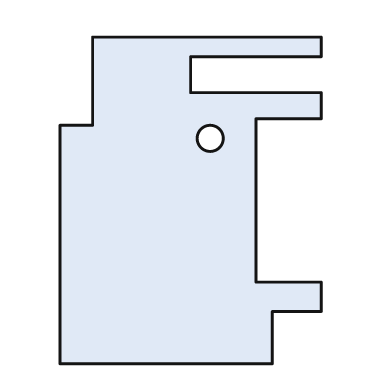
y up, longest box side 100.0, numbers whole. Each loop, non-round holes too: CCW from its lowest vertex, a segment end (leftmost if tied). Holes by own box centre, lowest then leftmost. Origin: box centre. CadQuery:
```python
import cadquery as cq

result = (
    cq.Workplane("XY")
    .moveTo(-40.0, -50.0)
    .lineTo(25.0, -50.0)
    .lineTo(25.0, -34.0)
    .lineTo(40.0, -34.0)
    .lineTo(40.0, -25.0)
    .lineTo(20.0, -25.0)
    .lineTo(20.0, 25.0)
    .lineTo(40.0, 25.0)
    .lineTo(40.0, 33.0)
    .lineTo(0.0, 33.0)
    .lineTo(0.0, 44.0)
    .lineTo(40.0, 44.0)
    .lineTo(40.0, 50.0)
    .lineTo(-30.0, 50.0)
    .lineTo(-30.0, 23.0)
    .lineTo(-40.0, 23.0)
    .close()
    .moveTo(6.0, 19.0)
    .circle(4.0)
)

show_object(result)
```